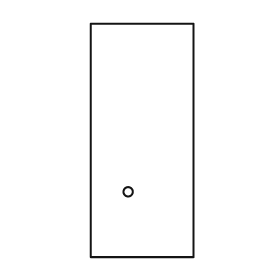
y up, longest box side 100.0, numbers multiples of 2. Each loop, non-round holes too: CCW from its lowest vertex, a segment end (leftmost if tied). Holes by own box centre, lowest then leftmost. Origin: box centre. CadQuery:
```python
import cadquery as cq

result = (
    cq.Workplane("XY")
    .moveTo(-22.0, -50.0)
    .lineTo(22.0, -50.0)
    .lineTo(22.0, 50.0)
    .lineTo(-22.0, 50.0)
    .close()
    .moveTo(-6.0, -22.0)
    .circle(2.0)
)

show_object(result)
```